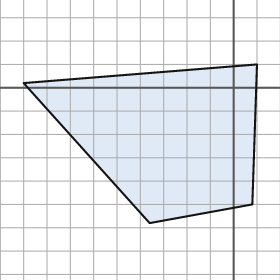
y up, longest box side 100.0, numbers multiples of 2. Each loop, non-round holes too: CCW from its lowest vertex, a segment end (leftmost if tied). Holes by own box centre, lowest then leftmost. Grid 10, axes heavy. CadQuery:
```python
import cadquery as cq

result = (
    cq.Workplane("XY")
    .moveTo(-36.0, -58.0)
    .lineTo(8.0, -50.0)
    .lineTo(10.0, 10.0)
    .lineTo(-90.0, 2.0)
    .close()
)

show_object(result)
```